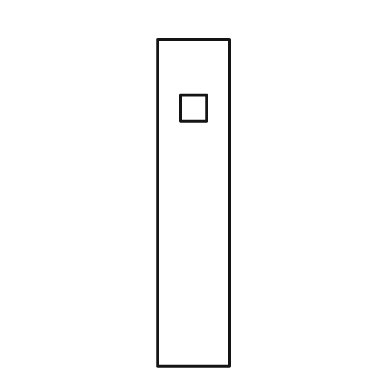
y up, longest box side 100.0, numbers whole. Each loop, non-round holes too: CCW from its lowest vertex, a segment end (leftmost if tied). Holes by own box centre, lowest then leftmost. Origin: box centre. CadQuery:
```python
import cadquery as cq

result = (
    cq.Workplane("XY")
    .moveTo(-11.0, -50.0)
    .lineTo(11.0, -50.0)
    .lineTo(11.0, 50.0)
    .lineTo(-11.0, 50.0)
    .close()
    .moveTo(-4.0, 25.0)
    .lineTo(4.0, 25.0)
    .lineTo(4.0, 33.0)
    .lineTo(-4.0, 33.0)
    .close()
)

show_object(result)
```